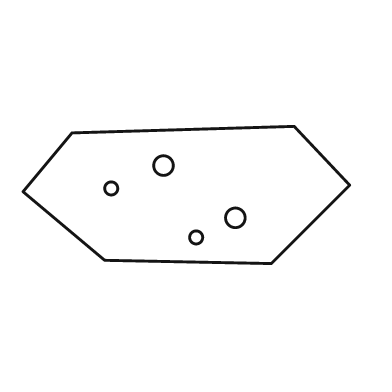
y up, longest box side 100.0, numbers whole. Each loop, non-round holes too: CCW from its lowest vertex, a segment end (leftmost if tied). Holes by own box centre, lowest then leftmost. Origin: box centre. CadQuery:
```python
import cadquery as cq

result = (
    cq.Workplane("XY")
    .moveTo(26.0, -21.0)
    .lineTo(50.0, 3.0)
    .lineTo(33.0, 21.0)
    .lineTo(-35.0, 19.0)
    .lineTo(-50.0, 1.0)
    .lineTo(-25.0, -20.0)
    .close()
    .moveTo(3.0, -13.0)
    .circle(2.0)
    .moveTo(15.0, -7.0)
    .circle(3.0)
    .moveTo(-23.0, 2.0)
    .circle(2.0)
    .moveTo(-7.0, 9.0)
    .circle(3.0)
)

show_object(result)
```